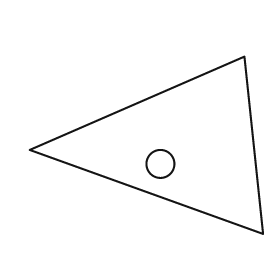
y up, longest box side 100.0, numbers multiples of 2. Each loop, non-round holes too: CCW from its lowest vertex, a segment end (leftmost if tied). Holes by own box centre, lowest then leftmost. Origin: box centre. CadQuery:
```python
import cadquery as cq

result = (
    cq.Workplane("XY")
    .moveTo(50.0, -38.0)
    .lineTo(42.0, 38.0)
    .lineTo(-50.0, -2.0)
    .close()
    .moveTo(6.0, -8.0)
    .circle(6.0)
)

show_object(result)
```